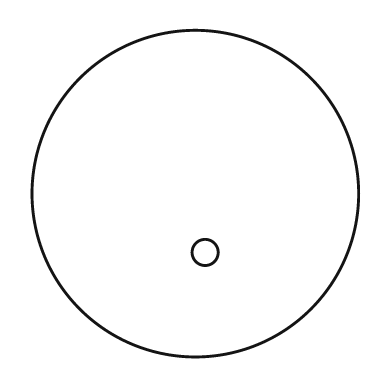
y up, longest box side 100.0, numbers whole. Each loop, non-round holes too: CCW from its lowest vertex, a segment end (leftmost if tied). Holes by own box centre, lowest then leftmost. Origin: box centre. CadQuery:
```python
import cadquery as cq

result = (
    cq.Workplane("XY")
    .moveTo(0.0, 0.0)
    .circle(50.0)
    .moveTo(3.0, -18.0)
    .circle(4.0)
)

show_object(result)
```